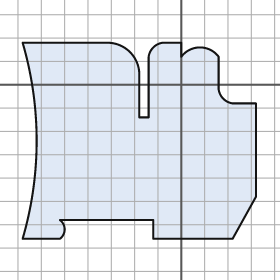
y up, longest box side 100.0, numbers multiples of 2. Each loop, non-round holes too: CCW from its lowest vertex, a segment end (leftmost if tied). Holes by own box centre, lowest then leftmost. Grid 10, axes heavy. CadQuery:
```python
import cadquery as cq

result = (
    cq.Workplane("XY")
    .moveTo(-68.0, -66.0)
    .lineTo(-52.0, -66.0)
    .threePointArc((-50.0, -62.0), (-52.0, -58.0))
    .lineTo(-12.0, -58.0)
    .lineTo(-12.0, -66.0)
    .lineTo(22.0, -66.0)
    .lineTo(32.0, -48.0)
    .lineTo(32.0, -8.0)
    .lineTo(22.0, -8.0)
    .threePointArc((18.0, -6.0), (16.0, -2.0))
    .lineTo(16.0, 12.0)
    .threePointArc((8.0, 16.0), (0.0, 12.0))
    .lineTo(0.0, 18.0)
    .lineTo(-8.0, 18.0)
    .threePointArc((-12.0, 16.0), (-14.0, 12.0))
    .lineTo(-14.0, -14.0)
    .lineTo(-18.0, -14.0)
    .lineTo(-18.0, 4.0)
    .threePointArc((-22.0, 14.0), (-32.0, 18.0))
    .lineTo(-68.0, 18.0)
    .threePointArc((-62.0, -24.0), (-68.0, -66.0))
    .close()
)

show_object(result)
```